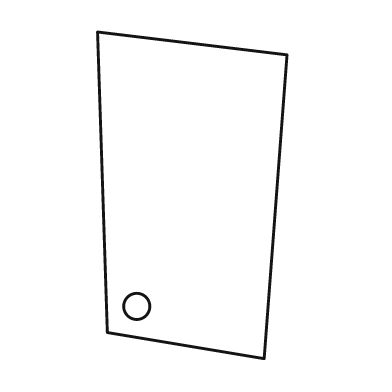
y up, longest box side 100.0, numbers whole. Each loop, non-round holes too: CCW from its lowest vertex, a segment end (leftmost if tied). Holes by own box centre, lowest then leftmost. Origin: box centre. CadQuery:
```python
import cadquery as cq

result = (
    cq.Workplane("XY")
    .moveTo(22.0, -50.0)
    .lineTo(29.0, 43.0)
    .lineTo(-29.0, 50.0)
    .lineTo(-26.0, -42.0)
    .close()
    .moveTo(-17.0, -34.0)
    .circle(4.0)
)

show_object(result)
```